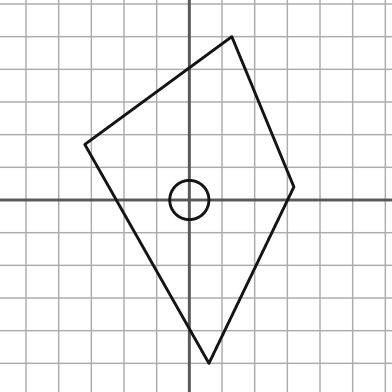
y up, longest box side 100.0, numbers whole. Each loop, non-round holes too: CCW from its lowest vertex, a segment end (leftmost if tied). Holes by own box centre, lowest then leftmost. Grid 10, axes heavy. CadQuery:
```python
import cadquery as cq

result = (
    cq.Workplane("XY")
    .moveTo(6.0, -50.0)
    .lineTo(32.0, 4.0)
    .lineTo(13.0, 50.0)
    .lineTo(-32.0, 17.0)
    .close()
    .moveTo(0.0, 0.0)
    .circle(6.0)
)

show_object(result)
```